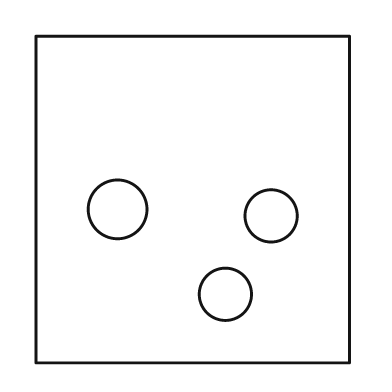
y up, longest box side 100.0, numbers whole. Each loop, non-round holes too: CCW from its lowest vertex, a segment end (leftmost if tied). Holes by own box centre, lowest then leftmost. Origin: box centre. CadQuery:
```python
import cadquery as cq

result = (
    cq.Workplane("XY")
    .moveTo(-48.0, -50.0)
    .lineTo(48.0, -50.0)
    .lineTo(48.0, 50.0)
    .lineTo(-48.0, 50.0)
    .close()
    .moveTo(10.0, -29.0)
    .circle(8.0)
    .moveTo(24.0, -5.0)
    .circle(8.0)
    .moveTo(-23.0, -3.0)
    .circle(9.0)
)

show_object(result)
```